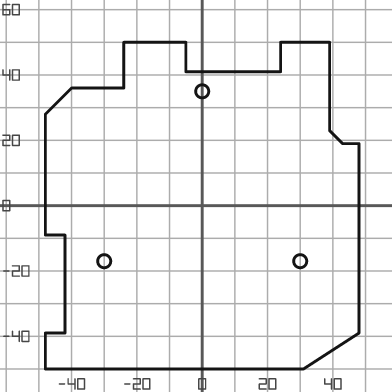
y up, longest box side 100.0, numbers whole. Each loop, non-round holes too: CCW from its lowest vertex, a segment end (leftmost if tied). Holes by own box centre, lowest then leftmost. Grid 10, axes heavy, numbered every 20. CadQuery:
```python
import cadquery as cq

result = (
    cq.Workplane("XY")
    .moveTo(-48.0, -50.0)
    .lineTo(31.0, -50.0)
    .lineTo(48.0, -39.0)
    .lineTo(48.0, 19.0)
    .lineTo(43.0, 19.0)
    .lineTo(39.0, 23.0)
    .lineTo(39.0, 50.0)
    .lineTo(24.0, 50.0)
    .lineTo(24.0, 41.0)
    .lineTo(-5.0, 41.0)
    .lineTo(-5.0, 50.0)
    .lineTo(-24.0, 50.0)
    .lineTo(-24.0, 36.0)
    .lineTo(-40.0, 36.0)
    .lineTo(-48.0, 28.0)
    .lineTo(-48.0, -9.0)
    .lineTo(-42.0, -9.0)
    .lineTo(-42.0, -39.0)
    .lineTo(-48.0, -39.0)
    .close()
    .moveTo(-30.0, -17.0)
    .circle(2.0)
    .moveTo(30.0, -17.0)
    .circle(2.0)
    .moveTo(0.0, 35.0)
    .circle(2.0)
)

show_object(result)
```